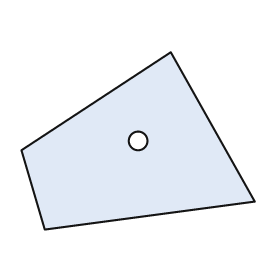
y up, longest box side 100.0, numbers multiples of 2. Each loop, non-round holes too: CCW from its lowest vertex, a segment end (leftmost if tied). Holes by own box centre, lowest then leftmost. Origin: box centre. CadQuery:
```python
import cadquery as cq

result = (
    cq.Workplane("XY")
    .moveTo(-40.0, -38.0)
    .lineTo(50.0, -26.0)
    .lineTo(14.0, 38.0)
    .lineTo(-50.0, -4.0)
    .close()
    .moveTo(0.0, 0.0)
    .circle(4.0)
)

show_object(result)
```